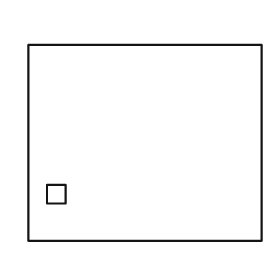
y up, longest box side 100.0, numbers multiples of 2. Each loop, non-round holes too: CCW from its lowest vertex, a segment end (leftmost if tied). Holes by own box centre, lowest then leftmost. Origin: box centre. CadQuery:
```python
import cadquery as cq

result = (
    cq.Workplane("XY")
    .moveTo(-50.0, -42.0)
    .lineTo(50.0, -42.0)
    .lineTo(50.0, 42.0)
    .lineTo(-50.0, 42.0)
    .close()
    .moveTo(-42.0, -26.0)
    .lineTo(-34.0, -26.0)
    .lineTo(-34.0, -18.0)
    .lineTo(-42.0, -18.0)
    .close()
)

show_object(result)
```